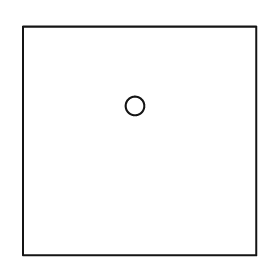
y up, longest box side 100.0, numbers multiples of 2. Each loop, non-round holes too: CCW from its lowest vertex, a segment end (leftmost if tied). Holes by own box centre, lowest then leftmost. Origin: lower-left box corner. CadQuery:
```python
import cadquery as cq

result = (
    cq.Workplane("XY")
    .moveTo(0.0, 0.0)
    .lineTo(100.0, 0.0)
    .lineTo(100.0, 98.0)
    .lineTo(0.0, 98.0)
    .close()
    .moveTo(48.0, 64.0)
    .circle(4.0)
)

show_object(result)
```